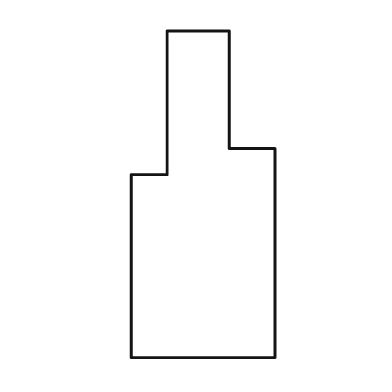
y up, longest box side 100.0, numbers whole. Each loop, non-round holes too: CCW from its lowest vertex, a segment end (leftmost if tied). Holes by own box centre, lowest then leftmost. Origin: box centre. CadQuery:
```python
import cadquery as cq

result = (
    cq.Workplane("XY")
    .moveTo(-22.0, -50.0)
    .lineTo(22.0, -50.0)
    .lineTo(22.0, 14.0)
    .lineTo(8.0, 14.0)
    .lineTo(8.0, 50.0)
    .lineTo(-11.0, 50.0)
    .lineTo(-11.0, 6.0)
    .lineTo(-22.0, 6.0)
    .close()
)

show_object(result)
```